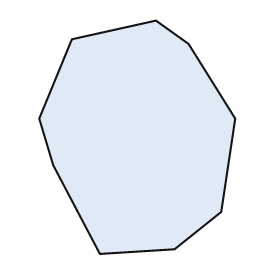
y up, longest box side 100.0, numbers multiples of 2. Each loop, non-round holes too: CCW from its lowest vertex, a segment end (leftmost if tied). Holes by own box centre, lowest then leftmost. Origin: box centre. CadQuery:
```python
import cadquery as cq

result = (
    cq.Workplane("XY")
    .moveTo(-16.0, -50.0)
    .lineTo(16.0, -48.0)
    .lineTo(36.0, -32.0)
    .lineTo(42.0, 8.0)
    .lineTo(22.0, 40.0)
    .lineTo(8.0, 50.0)
    .lineTo(-28.0, 42.0)
    .lineTo(-42.0, 8.0)
    .lineTo(-36.0, -12.0)
    .close()
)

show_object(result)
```